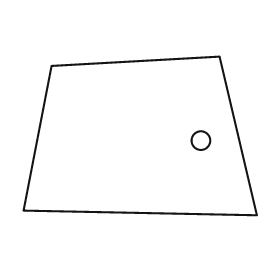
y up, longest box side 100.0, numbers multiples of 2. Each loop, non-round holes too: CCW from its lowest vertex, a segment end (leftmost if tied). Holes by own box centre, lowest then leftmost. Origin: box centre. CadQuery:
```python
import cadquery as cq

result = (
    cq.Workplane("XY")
    .moveTo(50.0, -34.0)
    .lineTo(34.0, 34.0)
    .lineTo(-38.0, 30.0)
    .lineTo(-50.0, -32.0)
    .close()
    .moveTo(26.0, -2.0)
    .circle(4.0)
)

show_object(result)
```